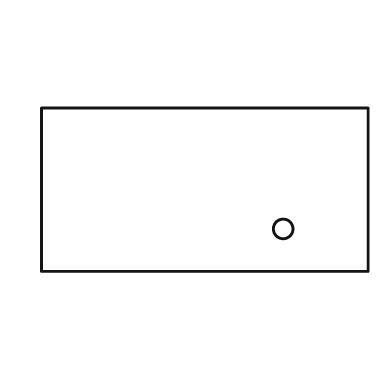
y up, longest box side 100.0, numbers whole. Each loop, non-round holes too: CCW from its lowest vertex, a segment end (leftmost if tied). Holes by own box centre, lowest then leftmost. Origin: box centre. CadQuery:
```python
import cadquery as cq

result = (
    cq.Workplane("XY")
    .moveTo(-50.0, -25.0)
    .lineTo(50.0, -25.0)
    .lineTo(50.0, 25.0)
    .lineTo(-50.0, 25.0)
    .close()
    .moveTo(24.0, -12.0)
    .circle(3.0)
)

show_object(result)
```